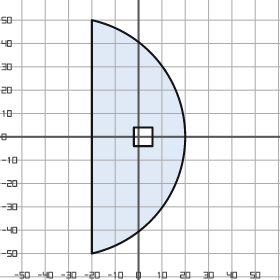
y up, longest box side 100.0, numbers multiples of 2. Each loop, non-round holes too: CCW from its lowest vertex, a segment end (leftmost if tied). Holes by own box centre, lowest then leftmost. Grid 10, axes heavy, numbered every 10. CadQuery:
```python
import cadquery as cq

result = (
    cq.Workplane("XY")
    .moveTo(-20.0, -50.0)
    .threePointArc((20.0, 0.0), (-20.0, 50.0))
    .close()
    .moveTo(-2.0, -4.0)
    .lineTo(6.0, -4.0)
    .lineTo(6.0, 4.0)
    .lineTo(-2.0, 4.0)
    .close()
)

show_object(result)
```